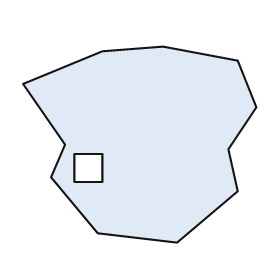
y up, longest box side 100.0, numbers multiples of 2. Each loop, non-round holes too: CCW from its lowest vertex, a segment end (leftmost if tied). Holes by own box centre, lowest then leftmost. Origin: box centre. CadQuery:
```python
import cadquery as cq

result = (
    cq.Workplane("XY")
    .moveTo(16.0, -42.0)
    .lineTo(42.0, -20.0)
    .lineTo(38.0, -2.0)
    .lineTo(50.0, 16.0)
    .lineTo(42.0, 36.0)
    .lineTo(10.0, 42.0)
    .lineTo(-16.0, 40.0)
    .lineTo(-50.0, 26.0)
    .lineTo(-32.0, 0.0)
    .lineTo(-38.0, -14.0)
    .lineTo(-18.0, -38.0)
    .close()
    .moveTo(-28.0, -16.0)
    .lineTo(-16.0, -16.0)
    .lineTo(-16.0, -4.0)
    .lineTo(-28.0, -4.0)
    .close()
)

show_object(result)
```